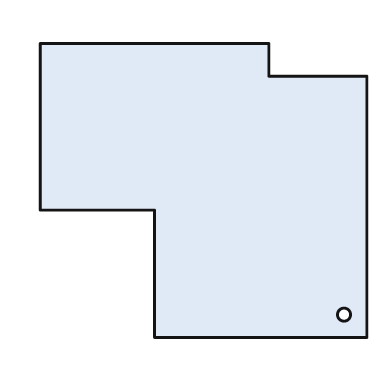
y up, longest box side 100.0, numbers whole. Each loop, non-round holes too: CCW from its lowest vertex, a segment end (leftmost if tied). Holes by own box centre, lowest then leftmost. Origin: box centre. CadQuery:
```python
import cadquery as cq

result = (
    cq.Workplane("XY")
    .moveTo(-15.0, -45.0)
    .lineTo(50.0, -45.0)
    .lineTo(50.0, 35.0)
    .lineTo(20.0, 35.0)
    .lineTo(20.0, 45.0)
    .lineTo(-50.0, 45.0)
    .lineTo(-50.0, -6.0)
    .lineTo(-15.0, -6.0)
    .close()
    .moveTo(43.0, -38.0)
    .circle(2.0)
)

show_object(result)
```